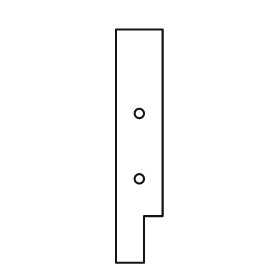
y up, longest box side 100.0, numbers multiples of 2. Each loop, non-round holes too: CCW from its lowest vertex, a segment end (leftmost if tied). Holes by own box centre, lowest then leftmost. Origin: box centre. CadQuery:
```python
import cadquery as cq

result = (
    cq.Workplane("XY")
    .moveTo(-10.0, -50.0)
    .lineTo(2.0, -50.0)
    .lineTo(2.0, -30.0)
    .lineTo(10.0, -30.0)
    .lineTo(10.0, 50.0)
    .lineTo(-10.0, 50.0)
    .close()
    .moveTo(0.0, -14.0)
    .circle(2.0)
    .moveTo(0.0, 14.0)
    .circle(2.0)
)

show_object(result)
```